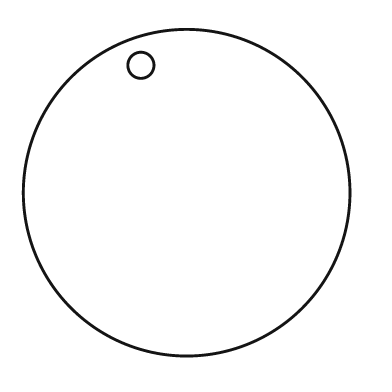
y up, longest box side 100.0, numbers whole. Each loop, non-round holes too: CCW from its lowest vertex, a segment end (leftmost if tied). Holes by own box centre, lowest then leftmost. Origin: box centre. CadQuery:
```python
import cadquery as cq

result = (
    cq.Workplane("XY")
    .moveTo(0.0, 0.0)
    .circle(50.0)
    .moveTo(-14.0, 39.0)
    .circle(4.0)
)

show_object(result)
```